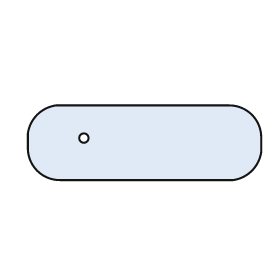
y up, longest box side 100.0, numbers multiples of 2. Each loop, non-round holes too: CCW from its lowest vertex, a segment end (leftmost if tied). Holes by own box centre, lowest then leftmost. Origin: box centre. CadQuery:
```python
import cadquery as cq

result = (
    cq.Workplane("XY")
    .moveTo(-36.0, -16.0)
    .lineTo(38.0, -16.0)
    .threePointArc((46.0, -12.0), (50.0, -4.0))
    .lineTo(50.0, 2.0)
    .threePointArc((46.0, 12.0), (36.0, 16.0))
    .lineTo(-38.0, 16.0)
    .threePointArc((-46.0, 12.0), (-50.0, 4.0))
    .lineTo(-50.0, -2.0)
    .threePointArc((-46.0, -12.0), (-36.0, -16.0))
    .close()
    .moveTo(-26.0, 2.0)
    .circle(2.0)
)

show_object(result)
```